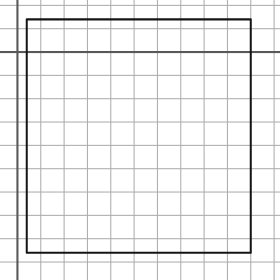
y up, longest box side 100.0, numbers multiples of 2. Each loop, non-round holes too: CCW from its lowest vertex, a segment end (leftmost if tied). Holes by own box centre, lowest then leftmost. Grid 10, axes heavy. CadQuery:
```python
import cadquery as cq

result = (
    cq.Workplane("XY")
    .moveTo(4.0, -86.0)
    .lineTo(100.0, -86.0)
    .lineTo(100.0, 14.0)
    .lineTo(4.0, 14.0)
    .close()
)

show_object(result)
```